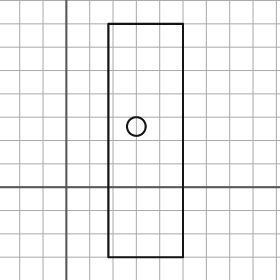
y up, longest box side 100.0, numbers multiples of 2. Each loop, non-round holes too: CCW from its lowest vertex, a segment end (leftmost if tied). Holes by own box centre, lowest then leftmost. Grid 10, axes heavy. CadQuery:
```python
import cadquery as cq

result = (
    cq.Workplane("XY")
    .moveTo(18.0, -30.0)
    .lineTo(50.0, -30.0)
    .lineTo(50.0, 70.0)
    .lineTo(18.0, 70.0)
    .close()
    .moveTo(30.0, 26.0)
    .circle(4.0)
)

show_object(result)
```